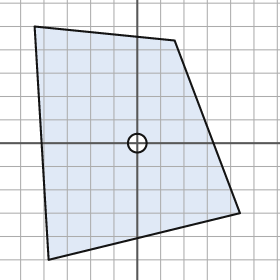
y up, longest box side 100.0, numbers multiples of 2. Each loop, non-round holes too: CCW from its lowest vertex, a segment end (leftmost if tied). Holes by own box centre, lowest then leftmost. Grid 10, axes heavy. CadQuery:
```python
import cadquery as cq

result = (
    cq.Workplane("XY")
    .moveTo(-38.0, -50.0)
    .lineTo(44.0, -30.0)
    .lineTo(16.0, 44.0)
    .lineTo(-44.0, 50.0)
    .close()
    .moveTo(0.0, 0.0)
    .circle(4.0)
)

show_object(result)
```